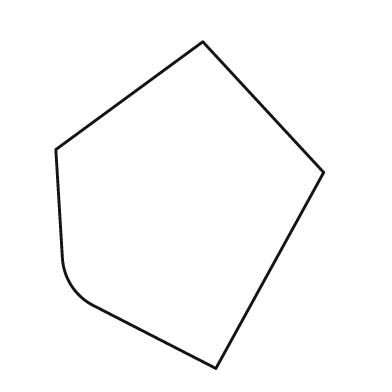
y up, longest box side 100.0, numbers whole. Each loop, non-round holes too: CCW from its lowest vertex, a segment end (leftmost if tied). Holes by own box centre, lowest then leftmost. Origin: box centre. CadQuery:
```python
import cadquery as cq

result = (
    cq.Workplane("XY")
    .moveTo(8.0, -50.0)
    .lineTo(41.0, 10.0)
    .lineTo(4.0, 50.0)
    .lineTo(-41.0, 17.0)
    .lineTo(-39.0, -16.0)
    .threePointArc((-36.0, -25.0), (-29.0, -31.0))
    .close()
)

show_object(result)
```